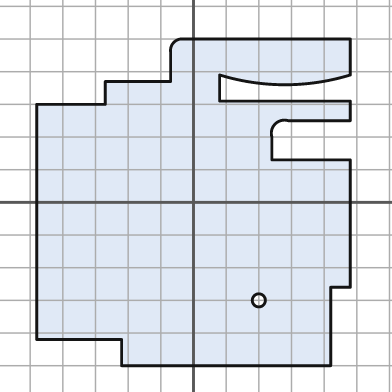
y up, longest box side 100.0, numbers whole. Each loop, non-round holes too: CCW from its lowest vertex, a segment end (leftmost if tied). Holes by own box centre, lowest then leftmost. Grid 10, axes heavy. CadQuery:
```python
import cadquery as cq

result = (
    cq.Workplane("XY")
    .moveTo(-22.0, -50.0)
    .lineTo(42.0, -50.0)
    .lineTo(42.0, -26.0)
    .lineTo(48.0, -26.0)
    .lineTo(48.0, 13.0)
    .lineTo(24.0, 13.0)
    .lineTo(24.0, 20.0)
    .threePointArc((25.0, 24.0), (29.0, 25.0))
    .lineTo(48.0, 25.0)
    .lineTo(48.0, 31.0)
    .lineTo(8.0, 31.0)
    .lineTo(8.0, 39.0)
    .threePointArc((28.0, 36.0), (48.0, 39.0))
    .lineTo(48.0, 50.0)
    .lineTo(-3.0, 50.0)
    .threePointArc((-6.0, 49.0), (-7.0, 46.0))
    .lineTo(-7.0, 37.0)
    .lineTo(-27.0, 37.0)
    .lineTo(-27.0, 30.0)
    .lineTo(-48.0, 30.0)
    .lineTo(-48.0, -42.0)
    .lineTo(-22.0, -42.0)
    .close()
    .moveTo(20.0, -30.0)
    .circle(2.0)
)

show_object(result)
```